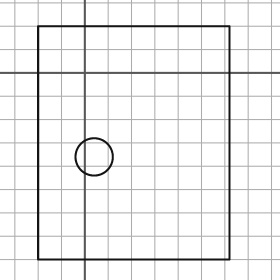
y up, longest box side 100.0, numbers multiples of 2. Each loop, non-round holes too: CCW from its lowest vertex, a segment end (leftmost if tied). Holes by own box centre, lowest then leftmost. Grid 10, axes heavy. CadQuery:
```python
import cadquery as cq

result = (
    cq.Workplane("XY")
    .moveTo(-20.0, -80.0)
    .lineTo(62.0, -80.0)
    .lineTo(62.0, 20.0)
    .lineTo(-20.0, 20.0)
    .close()
    .moveTo(4.0, -36.0)
    .circle(8.0)
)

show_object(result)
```